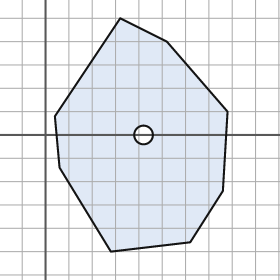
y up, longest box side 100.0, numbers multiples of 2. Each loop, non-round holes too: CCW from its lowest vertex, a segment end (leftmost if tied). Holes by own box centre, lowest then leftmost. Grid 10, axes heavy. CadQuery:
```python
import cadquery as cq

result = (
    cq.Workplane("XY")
    .moveTo(28.0, -50.0)
    .lineTo(62.0, -46.0)
    .lineTo(76.0, -24.0)
    .lineTo(78.0, 10.0)
    .lineTo(52.0, 40.0)
    .lineTo(32.0, 50.0)
    .lineTo(4.0, 8.0)
    .lineTo(6.0, -14.0)
    .close()
    .moveTo(42.0, 0.0)
    .circle(4.0)
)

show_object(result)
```